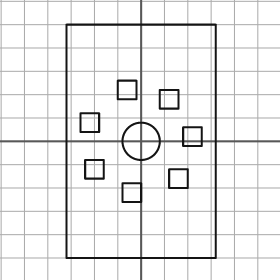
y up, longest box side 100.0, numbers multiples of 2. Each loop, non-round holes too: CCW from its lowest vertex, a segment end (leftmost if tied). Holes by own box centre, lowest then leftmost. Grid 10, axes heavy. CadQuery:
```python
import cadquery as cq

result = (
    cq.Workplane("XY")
    .moveTo(-32.0, -50.0)
    .lineTo(32.0, -50.0)
    .lineTo(32.0, 50.0)
    .lineTo(-32.0, 50.0)
    .close()
    .moveTo(-8.0, -26.0)
    .lineTo(0.0, -26.0)
    .lineTo(0.0, -18.0)
    .lineTo(-8.0, -18.0)
    .close()
    .moveTo(12.0, -20.0)
    .lineTo(20.0, -20.0)
    .lineTo(20.0, -12.0)
    .lineTo(12.0, -12.0)
    .close()
    .moveTo(-24.0, -16.0)
    .lineTo(-16.0, -16.0)
    .lineTo(-16.0, -8.0)
    .lineTo(-24.0, -8.0)
    .close()
    .moveTo(0.0, 0.0)
    .circle(8.0)
    .moveTo(18.0, -2.0)
    .lineTo(26.0, -2.0)
    .lineTo(26.0, 6.0)
    .lineTo(18.0, 6.0)
    .close()
    .moveTo(-26.0, 4.0)
    .lineTo(-18.0, 4.0)
    .lineTo(-18.0, 12.0)
    .lineTo(-26.0, 12.0)
    .close()
    .moveTo(8.0, 14.0)
    .lineTo(16.0, 14.0)
    .lineTo(16.0, 22.0)
    .lineTo(8.0, 22.0)
    .close()
    .moveTo(-10.0, 18.0)
    .lineTo(-2.0, 18.0)
    .lineTo(-2.0, 26.0)
    .lineTo(-10.0, 26.0)
    .close()
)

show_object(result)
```